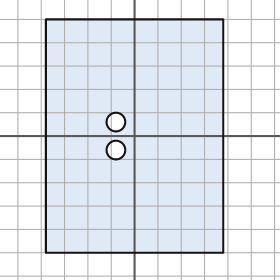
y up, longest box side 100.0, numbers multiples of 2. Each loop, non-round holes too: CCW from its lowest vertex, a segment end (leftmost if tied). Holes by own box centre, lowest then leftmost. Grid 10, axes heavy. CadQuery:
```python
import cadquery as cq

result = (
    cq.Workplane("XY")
    .moveTo(-38.0, -50.0)
    .lineTo(38.0, -50.0)
    .lineTo(38.0, 50.0)
    .lineTo(-38.0, 50.0)
    .close()
    .moveTo(-8.0, -6.0)
    .circle(4.0)
    .moveTo(-8.0, 6.0)
    .circle(4.0)
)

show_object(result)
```